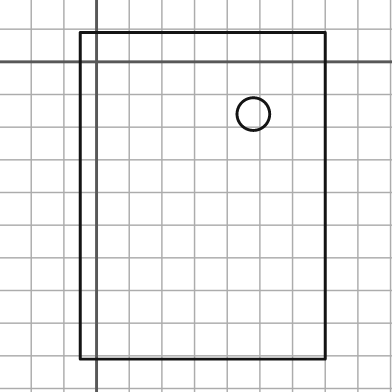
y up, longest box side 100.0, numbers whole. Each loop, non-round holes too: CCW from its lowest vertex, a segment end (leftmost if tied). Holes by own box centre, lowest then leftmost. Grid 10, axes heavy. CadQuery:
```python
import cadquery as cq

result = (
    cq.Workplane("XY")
    .moveTo(-5.0, -91.0)
    .lineTo(70.0, -91.0)
    .lineTo(70.0, 9.0)
    .lineTo(-5.0, 9.0)
    .close()
    .moveTo(48.0, -16.0)
    .circle(5.0)
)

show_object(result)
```